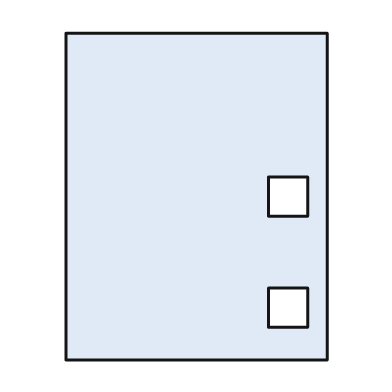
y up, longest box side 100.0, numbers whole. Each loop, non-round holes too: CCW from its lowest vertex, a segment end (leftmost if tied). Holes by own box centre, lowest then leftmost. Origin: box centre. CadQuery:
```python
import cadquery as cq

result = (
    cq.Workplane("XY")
    .moveTo(-40.0, -50.0)
    .lineTo(40.0, -50.0)
    .lineTo(40.0, 50.0)
    .lineTo(-40.0, 50.0)
    .close()
    .moveTo(22.0, -40.0)
    .lineTo(34.0, -40.0)
    .lineTo(34.0, -28.0)
    .lineTo(22.0, -28.0)
    .close()
    .moveTo(22.0, -6.0)
    .lineTo(34.0, -6.0)
    .lineTo(34.0, 6.0)
    .lineTo(22.0, 6.0)
    .close()
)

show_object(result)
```